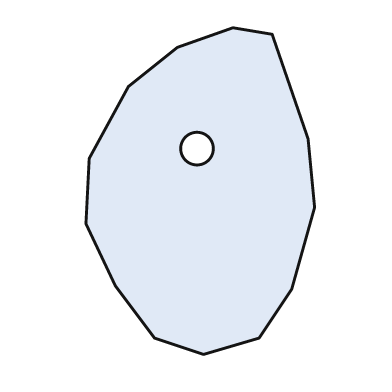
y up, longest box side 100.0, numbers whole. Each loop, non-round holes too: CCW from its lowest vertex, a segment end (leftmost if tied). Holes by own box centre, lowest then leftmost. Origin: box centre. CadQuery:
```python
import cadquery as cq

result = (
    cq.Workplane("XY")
    .moveTo(1.0, -50.0)
    .lineTo(18.0, -45.0)
    .lineTo(28.0, -30.0)
    .lineTo(35.0, -5.0)
    .lineTo(33.0, 16.0)
    .lineTo(22.0, 48.0)
    .lineTo(10.0, 50.0)
    .lineTo(-7.0, 44.0)
    .lineTo(-22.0, 32.0)
    .lineTo(-34.0, 10.0)
    .lineTo(-35.0, -10.0)
    .lineTo(-26.0, -29.0)
    .lineTo(-14.0, -45.0)
    .close()
    .moveTo(-1.0, 13.0)
    .circle(5.0)
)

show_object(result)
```